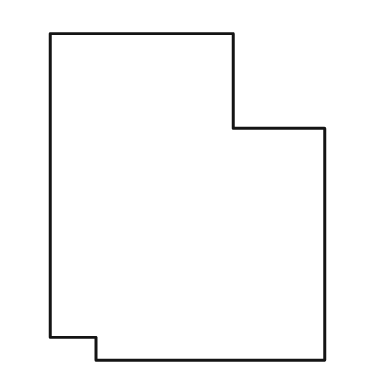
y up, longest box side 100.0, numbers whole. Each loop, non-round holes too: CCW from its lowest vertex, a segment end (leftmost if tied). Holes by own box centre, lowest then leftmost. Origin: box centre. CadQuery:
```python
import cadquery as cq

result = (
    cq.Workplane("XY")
    .moveTo(-28.0, -50.0)
    .lineTo(42.0, -50.0)
    .lineTo(42.0, 21.0)
    .lineTo(14.0, 21.0)
    .lineTo(14.0, 50.0)
    .lineTo(-42.0, 50.0)
    .lineTo(-42.0, -43.0)
    .lineTo(-28.0, -43.0)
    .close()
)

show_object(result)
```